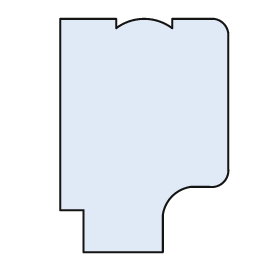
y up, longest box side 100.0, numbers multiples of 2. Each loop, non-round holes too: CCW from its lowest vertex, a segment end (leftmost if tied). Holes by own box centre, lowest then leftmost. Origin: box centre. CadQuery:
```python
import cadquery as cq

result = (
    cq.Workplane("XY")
    .moveTo(-26.0, -50.0)
    .lineTo(8.0, -50.0)
    .lineTo(8.0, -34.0)
    .threePointArc((12.0, -26.0), (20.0, -22.0))
    .lineTo(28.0, -22.0)
    .threePointArc((34.0, -20.0), (36.0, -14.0))
    .lineTo(36.0, 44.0)
    .threePointArc((34.0, 48.0), (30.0, 50.0))
    .lineTo(12.0, 50.0)
    .lineTo(12.0, 46.0)
    .threePointArc((0.0, 50.0), (-12.0, 46.0))
    .lineTo(-12.0, 50.0)
    .lineTo(-36.0, 50.0)
    .lineTo(-36.0, -32.0)
    .lineTo(-26.0, -32.0)
    .close()
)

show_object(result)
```